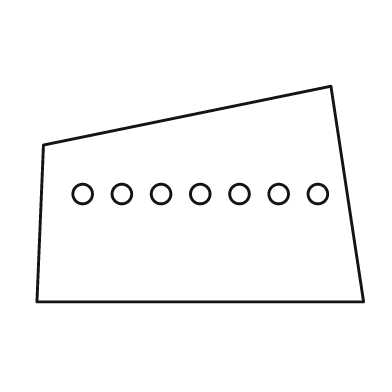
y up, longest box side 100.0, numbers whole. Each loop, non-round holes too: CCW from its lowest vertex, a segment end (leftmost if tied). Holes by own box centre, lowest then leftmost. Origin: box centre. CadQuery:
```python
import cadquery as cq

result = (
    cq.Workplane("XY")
    .moveTo(-50.0, -33.0)
    .lineTo(50.0, -33.0)
    .lineTo(40.0, 33.0)
    .lineTo(-48.0, 15.0)
    .close()
    .moveTo(-36.0, 0.0)
    .circle(3.0)
    .moveTo(-24.0, 0.0)
    .circle(3.0)
    .moveTo(-12.0, 0.0)
    .circle(3.0)
    .moveTo(0.0, 0.0)
    .circle(3.0)
    .moveTo(12.0, 0.0)
    .circle(3.0)
    .moveTo(24.0, 0.0)
    .circle(3.0)
    .moveTo(36.0, 0.0)
    .circle(3.0)
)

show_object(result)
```